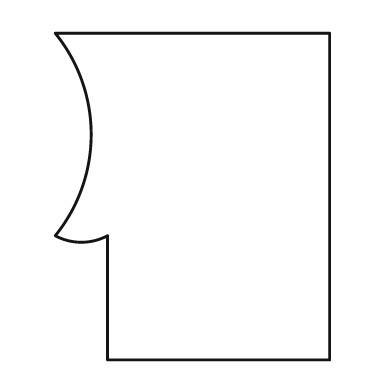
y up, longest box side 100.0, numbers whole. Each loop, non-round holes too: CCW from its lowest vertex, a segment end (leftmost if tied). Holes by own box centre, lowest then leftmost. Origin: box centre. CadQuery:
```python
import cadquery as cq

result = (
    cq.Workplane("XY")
    .moveTo(-26.0, -50.0)
    .lineTo(42.0, -50.0)
    .lineTo(42.0, 50.0)
    .lineTo(-42.0, 50.0)
    .threePointArc((-31.0, 19.0), (-42.0, -12.0))
    .threePointArc((-34.0, -14.0), (-26.0, -12.0))
    .close()
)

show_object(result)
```